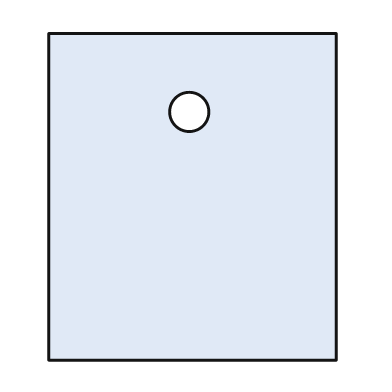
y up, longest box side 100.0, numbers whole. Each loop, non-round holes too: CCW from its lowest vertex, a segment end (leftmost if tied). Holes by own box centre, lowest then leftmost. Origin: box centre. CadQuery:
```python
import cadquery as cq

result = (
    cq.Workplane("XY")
    .moveTo(-44.0, -50.0)
    .lineTo(44.0, -50.0)
    .lineTo(44.0, 50.0)
    .lineTo(-44.0, 50.0)
    .close()
    .moveTo(-1.0, 26.0)
    .circle(6.0)
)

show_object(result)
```